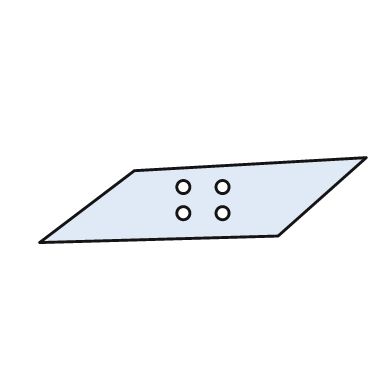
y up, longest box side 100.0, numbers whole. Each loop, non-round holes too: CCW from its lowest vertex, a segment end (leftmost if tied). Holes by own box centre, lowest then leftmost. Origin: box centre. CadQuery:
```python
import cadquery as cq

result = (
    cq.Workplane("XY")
    .moveTo(-50.0, -13.0)
    .lineTo(23.0, -11.0)
    .lineTo(50.0, 13.0)
    .lineTo(-21.0, 9.0)
    .close()
    .moveTo(-6.0, -4.0)
    .circle(2.0)
    .moveTo(6.0, -4.0)
    .circle(2.0)
    .moveTo(-6.0, 4.0)
    .circle(2.0)
    .moveTo(6.0, 4.0)
    .circle(2.0)
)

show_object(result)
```